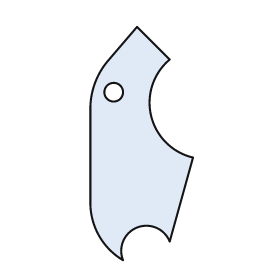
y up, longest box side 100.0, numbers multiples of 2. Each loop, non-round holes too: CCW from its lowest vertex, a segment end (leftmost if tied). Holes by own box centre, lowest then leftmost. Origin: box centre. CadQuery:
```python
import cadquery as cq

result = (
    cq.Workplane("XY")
    .moveTo(-8.0, -50.0)
    .threePointArc((-2.0, -36.0), (12.0, -42.0))
    .lineTo(22.0, -6.0)
    .threePointArc((4.0, 12.0), (12.0, 36.0))
    .lineTo(-2.0, 50.0)
    .lineTo(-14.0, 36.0)
    .threePointArc((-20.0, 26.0), (-22.0, 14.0))
    .lineTo(-22.0, -26.0)
    .threePointArc((-18.0, -40.0), (-8.0, -50.0))
    .close()
    .moveTo(-12.0, 22.0)
    .circle(4.0)
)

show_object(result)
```